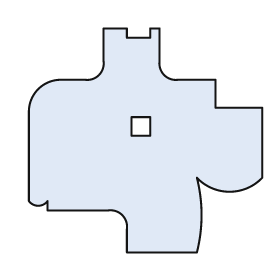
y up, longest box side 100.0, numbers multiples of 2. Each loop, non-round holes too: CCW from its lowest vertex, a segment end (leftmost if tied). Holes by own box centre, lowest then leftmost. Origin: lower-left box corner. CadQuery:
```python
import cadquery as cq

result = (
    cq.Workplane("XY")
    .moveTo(42.0, 0.0)
    .lineTo(72.0, 0.0)
    .threePointArc((74.0, 16.0), (72.0, 32.0))
    .threePointArc((86.0, 26.0), (100.0, 32.0))
    .lineTo(100.0, 62.0)
    .lineTo(80.0, 62.0)
    .lineTo(80.0, 74.0)
    .lineTo(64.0, 74.0)
    .threePointArc((58.0, 76.0), (56.0, 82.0))
    .lineTo(56.0, 96.0)
    .lineTo(52.0, 96.0)
    .lineTo(52.0, 92.0)
    .lineTo(42.0, 92.0)
    .lineTo(42.0, 96.0)
    .lineTo(32.0, 96.0)
    .lineTo(32.0, 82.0)
    .threePointArc((30.0, 76.0), (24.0, 74.0))
    .lineTo(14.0, 74.0)
    .threePointArc((4.0, 70.0), (0.0, 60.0))
    .lineTo(0.0, 22.0)
    .threePointArc((4.0, 20.0), (8.0, 22.0))
    .lineTo(8.0, 18.0)
    .lineTo(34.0, 18.0)
    .threePointArc((40.0, 16.0), (42.0, 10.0))
    .close()
    .moveTo(44.0, 50.0)
    .lineTo(52.0, 50.0)
    .lineTo(52.0, 58.0)
    .lineTo(44.0, 58.0)
    .close()
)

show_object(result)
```